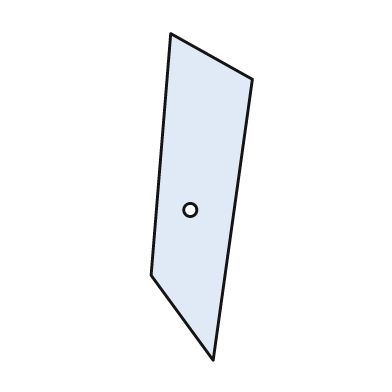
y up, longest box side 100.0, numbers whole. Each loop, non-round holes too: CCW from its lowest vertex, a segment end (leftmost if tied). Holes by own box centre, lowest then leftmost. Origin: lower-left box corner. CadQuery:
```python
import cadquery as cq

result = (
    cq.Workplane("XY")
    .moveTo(19.0, 0.0)
    .lineTo(31.0, 86.0)
    .lineTo(6.0, 100.0)
    .lineTo(0.0, 26.0)
    .close()
    .moveTo(12.0, 46.0)
    .circle(2.0)
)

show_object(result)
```